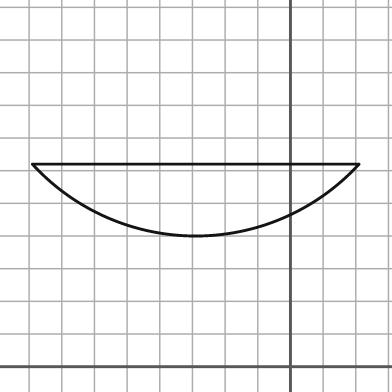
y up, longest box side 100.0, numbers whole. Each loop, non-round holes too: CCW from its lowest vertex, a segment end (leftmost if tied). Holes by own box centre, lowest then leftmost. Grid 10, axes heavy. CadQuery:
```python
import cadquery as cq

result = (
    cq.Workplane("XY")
    .moveTo(-79.0, 62.0)
    .threePointArc((-29.0, 40.0), (21.0, 62.0))
    .close()
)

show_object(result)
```